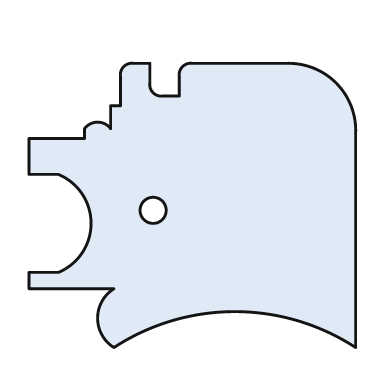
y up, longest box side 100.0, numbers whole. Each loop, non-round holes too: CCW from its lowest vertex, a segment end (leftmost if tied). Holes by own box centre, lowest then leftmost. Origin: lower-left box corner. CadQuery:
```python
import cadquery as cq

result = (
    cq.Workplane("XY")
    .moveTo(26.0, 0.0)
    .threePointArc((63.0, 11.0), (100.0, 0.0))
    .lineTo(100.0, 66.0)
    .threePointArc((94.0, 81.0), (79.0, 87.0))
    .lineTo(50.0, 87.0)
    .threePointArc((47.0, 86.0), (46.0, 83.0))
    .lineTo(46.0, 77.0)
    .lineTo(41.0, 77.0)
    .threePointArc((38.0, 78.0), (37.0, 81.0))
    .lineTo(37.0, 87.0)
    .lineTo(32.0, 87.0)
    .threePointArc((29.0, 86.0), (28.0, 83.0))
    .lineTo(28.0, 74.0)
    .lineTo(25.0, 74.0)
    .lineTo(25.0, 67.0)
    .threePointArc((21.0, 69.0), (17.0, 67.0))
    .lineTo(17.0, 64.0)
    .lineTo(0.0, 64.0)
    .lineTo(0.0, 53.0)
    .lineTo(9.0, 53.0)
    .threePointArc((19.0, 38.0), (9.0, 23.0))
    .lineTo(0.0, 23.0)
    .lineTo(0.0, 18.0)
    .lineTo(26.0, 18.0)
    .threePointArc((21.0, 9.0), (26.0, 0.0))
    .close()
    .moveTo(38.0, 42.0)
    .circle(4.0)
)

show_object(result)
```